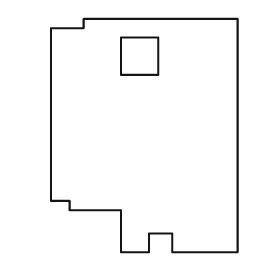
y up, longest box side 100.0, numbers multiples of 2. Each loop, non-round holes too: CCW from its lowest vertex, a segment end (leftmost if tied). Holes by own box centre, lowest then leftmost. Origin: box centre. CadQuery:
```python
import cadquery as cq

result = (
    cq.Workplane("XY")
    .moveTo(-10.0, -50.0)
    .lineTo(2.0, -50.0)
    .lineTo(2.0, -42.0)
    .lineTo(12.0, -42.0)
    .lineTo(12.0, -50.0)
    .lineTo(40.0, -50.0)
    .lineTo(40.0, 50.0)
    .lineTo(-26.0, 50.0)
    .lineTo(-26.0, 46.0)
    .lineTo(-40.0, 46.0)
    .lineTo(-40.0, -28.0)
    .lineTo(-32.0, -28.0)
    .lineTo(-32.0, -32.0)
    .lineTo(-10.0, -32.0)
    .close()
    .moveTo(-10.0, 26.0)
    .lineTo(6.0, 26.0)
    .lineTo(6.0, 42.0)
    .lineTo(-10.0, 42.0)
    .close()
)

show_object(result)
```